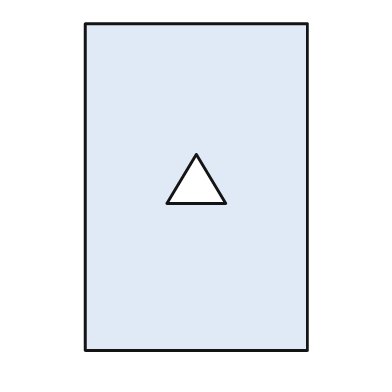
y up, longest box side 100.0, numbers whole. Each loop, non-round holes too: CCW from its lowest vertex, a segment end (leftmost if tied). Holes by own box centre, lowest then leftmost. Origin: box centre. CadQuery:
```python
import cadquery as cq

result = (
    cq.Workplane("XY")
    .moveTo(-34.0, -50.0)
    .lineTo(34.0, -50.0)
    .lineTo(34.0, 50.0)
    .lineTo(-34.0, 50.0)
    .close()
    .moveTo(-9.0, -5.0)
    .lineTo(9.0, -5.0)
    .lineTo(0.0, 10.0)
    .close()
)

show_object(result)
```